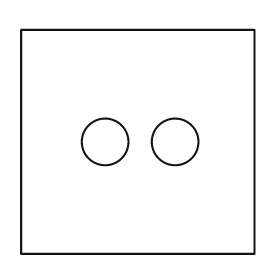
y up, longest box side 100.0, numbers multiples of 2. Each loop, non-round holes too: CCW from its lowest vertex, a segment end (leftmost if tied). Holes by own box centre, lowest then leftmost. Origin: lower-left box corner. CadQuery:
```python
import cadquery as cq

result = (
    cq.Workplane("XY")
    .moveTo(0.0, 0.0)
    .lineTo(100.0, 0.0)
    .lineTo(100.0, 96.0)
    .lineTo(0.0, 96.0)
    .close()
    .moveTo(36.0, 48.0)
    .circle(10.0)
    .moveTo(66.0, 48.0)
    .circle(10.0)
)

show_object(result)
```